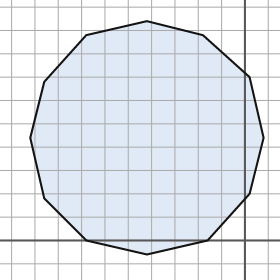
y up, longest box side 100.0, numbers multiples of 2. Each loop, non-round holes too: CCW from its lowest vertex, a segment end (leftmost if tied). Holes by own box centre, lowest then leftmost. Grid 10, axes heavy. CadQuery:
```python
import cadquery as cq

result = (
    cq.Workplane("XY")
    .moveTo(-42.0, -6.0)
    .lineTo(-16.0, 0.0)
    .lineTo(2.0, 20.0)
    .lineTo(8.0, 44.0)
    .lineTo(2.0, 70.0)
    .lineTo(-18.0, 88.0)
    .lineTo(-42.0, 94.0)
    .lineTo(-68.0, 88.0)
    .lineTo(-86.0, 68.0)
    .lineTo(-92.0, 44.0)
    .lineTo(-86.0, 18.0)
    .lineTo(-68.0, 0.0)
    .close()
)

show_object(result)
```